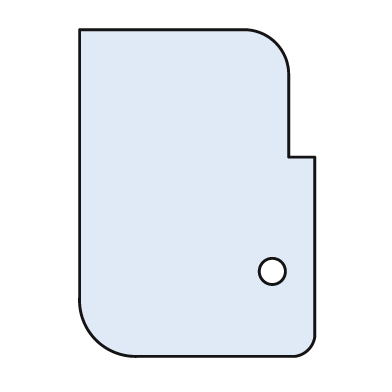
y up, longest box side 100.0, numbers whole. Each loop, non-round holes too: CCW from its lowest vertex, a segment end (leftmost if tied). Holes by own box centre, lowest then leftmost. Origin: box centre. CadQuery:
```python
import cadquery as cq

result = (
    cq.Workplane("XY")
    .moveTo(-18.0, -50.0)
    .lineTo(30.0, -50.0)
    .threePointArc((34.0, -48.0), (36.0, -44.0))
    .lineTo(36.0, 11.0)
    .lineTo(28.0, 11.0)
    .lineTo(28.0, 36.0)
    .threePointArc((24.0, 46.0), (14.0, 50.0))
    .lineTo(-36.0, 50.0)
    .lineTo(-36.0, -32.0)
    .threePointArc((-31.0, -45.0), (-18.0, -50.0))
    .close()
    .moveTo(23.0, -24.0)
    .circle(4.0)
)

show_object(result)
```